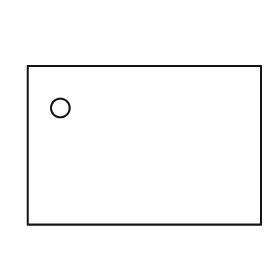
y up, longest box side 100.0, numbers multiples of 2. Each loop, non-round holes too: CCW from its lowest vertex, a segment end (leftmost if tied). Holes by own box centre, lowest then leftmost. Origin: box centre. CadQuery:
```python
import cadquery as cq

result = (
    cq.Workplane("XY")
    .moveTo(-50.0, -34.0)
    .lineTo(50.0, -34.0)
    .lineTo(50.0, 34.0)
    .lineTo(-50.0, 34.0)
    .close()
    .moveTo(-36.0, 16.0)
    .circle(4.0)
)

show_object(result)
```